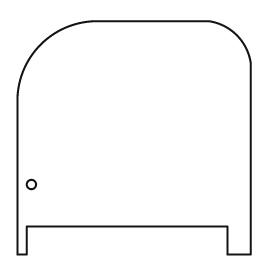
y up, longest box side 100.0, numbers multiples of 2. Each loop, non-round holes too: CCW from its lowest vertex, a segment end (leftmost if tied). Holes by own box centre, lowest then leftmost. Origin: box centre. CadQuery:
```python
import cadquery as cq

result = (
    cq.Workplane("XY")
    .moveTo(-50.0, -50.0)
    .lineTo(-46.0, -50.0)
    .lineTo(-46.0, -38.0)
    .lineTo(40.0, -38.0)
    .lineTo(40.0, -50.0)
    .lineTo(50.0, -50.0)
    .lineTo(50.0, 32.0)
    .threePointArc((44.0, 44.0), (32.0, 50.0))
    .lineTo(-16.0, 50.0)
    .threePointArc((-40.0, 40.0), (-50.0, 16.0))
    .close()
    .moveTo(-44.0, -20.0)
    .circle(2.0)
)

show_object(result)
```